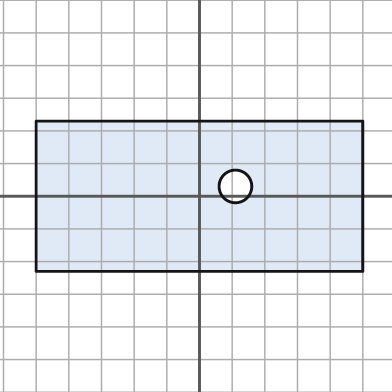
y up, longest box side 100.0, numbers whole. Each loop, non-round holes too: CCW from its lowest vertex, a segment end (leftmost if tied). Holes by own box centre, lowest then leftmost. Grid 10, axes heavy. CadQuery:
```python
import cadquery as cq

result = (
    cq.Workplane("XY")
    .moveTo(-50.0, -23.0)
    .lineTo(50.0, -23.0)
    .lineTo(50.0, 23.0)
    .lineTo(-50.0, 23.0)
    .close()
    .moveTo(11.0, 3.0)
    .circle(5.0)
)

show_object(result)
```